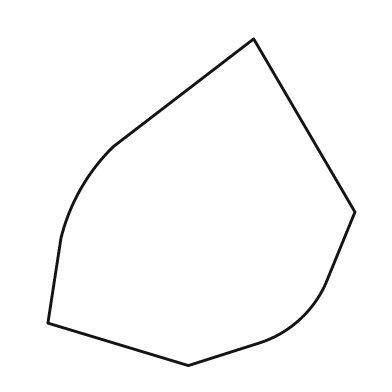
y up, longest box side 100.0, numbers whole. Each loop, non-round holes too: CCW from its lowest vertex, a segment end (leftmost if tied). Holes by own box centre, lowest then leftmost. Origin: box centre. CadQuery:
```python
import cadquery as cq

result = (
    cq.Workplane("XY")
    .moveTo(-4.0, -50.0)
    .lineTo(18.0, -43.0)
    .threePointArc((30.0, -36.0), (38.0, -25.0))
    .lineTo(47.0, -3.0)
    .lineTo(16.0, 50.0)
    .lineTo(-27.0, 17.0)
    .threePointArc((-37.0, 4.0), (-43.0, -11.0))
    .lineTo(-47.0, -37.0)
    .close()
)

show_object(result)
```